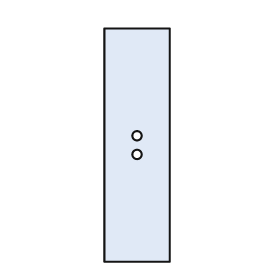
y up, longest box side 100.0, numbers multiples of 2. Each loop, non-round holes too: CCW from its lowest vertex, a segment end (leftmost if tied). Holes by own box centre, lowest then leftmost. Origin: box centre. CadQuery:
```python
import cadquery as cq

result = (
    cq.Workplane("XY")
    .moveTo(-14.0, -50.0)
    .lineTo(14.0, -50.0)
    .lineTo(14.0, 50.0)
    .lineTo(-14.0, 50.0)
    .close()
    .moveTo(0.0, -4.0)
    .circle(2.0)
    .moveTo(0.0, 4.0)
    .circle(2.0)
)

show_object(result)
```